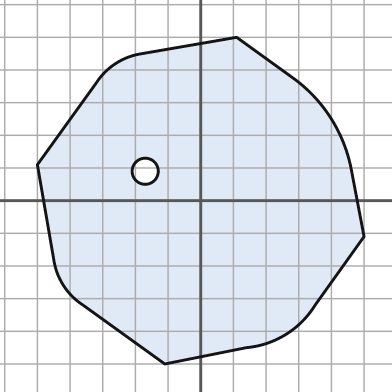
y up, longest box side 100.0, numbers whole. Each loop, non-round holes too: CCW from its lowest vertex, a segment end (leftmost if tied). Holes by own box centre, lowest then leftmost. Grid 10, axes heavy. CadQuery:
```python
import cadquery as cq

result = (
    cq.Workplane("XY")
    .moveTo(-11.0, -50.0)
    .lineTo(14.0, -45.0)
    .threePointArc((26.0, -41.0), (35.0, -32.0))
    .lineTo(50.0, -11.0)
    .lineTo(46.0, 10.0)
    .threePointArc((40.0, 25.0), (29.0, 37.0))
    .lineTo(11.0, 50.0)
    .lineTo(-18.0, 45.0)
    .threePointArc((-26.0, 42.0), (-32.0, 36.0))
    .lineTo(-50.0, 11.0)
    .lineTo(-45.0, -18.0)
    .threePointArc((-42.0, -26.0), (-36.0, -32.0))
    .close()
    .moveTo(-17.0, 9.0)
    .circle(4.0)
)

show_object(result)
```